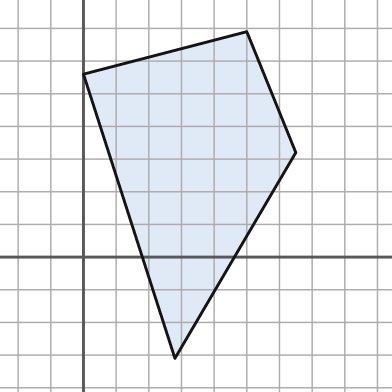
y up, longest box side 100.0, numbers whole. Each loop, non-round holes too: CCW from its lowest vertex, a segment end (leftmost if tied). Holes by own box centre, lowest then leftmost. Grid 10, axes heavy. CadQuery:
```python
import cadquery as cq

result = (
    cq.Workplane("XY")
    .moveTo(28.0, -31.0)
    .lineTo(65.0, 32.0)
    .lineTo(50.0, 69.0)
    .lineTo(0.0, 56.0)
    .close()
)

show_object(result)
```